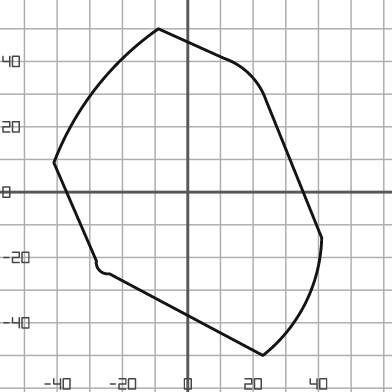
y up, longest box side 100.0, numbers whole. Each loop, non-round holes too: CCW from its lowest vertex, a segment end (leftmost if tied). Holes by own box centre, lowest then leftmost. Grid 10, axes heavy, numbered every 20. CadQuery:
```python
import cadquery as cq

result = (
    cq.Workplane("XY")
    .moveTo(23.0, -50.0)
    .threePointArc((36.0, -34.0), (41.0, -14.0))
    .lineTo(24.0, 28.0)
    .threePointArc((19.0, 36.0), (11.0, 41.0))
    .lineTo(-9.0, 50.0)
    .threePointArc((-28.0, 32.0), (-41.0, 9.0))
    .lineTo(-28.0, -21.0)
    .threePointArc((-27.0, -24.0), (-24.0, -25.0))
    .close()
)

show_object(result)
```